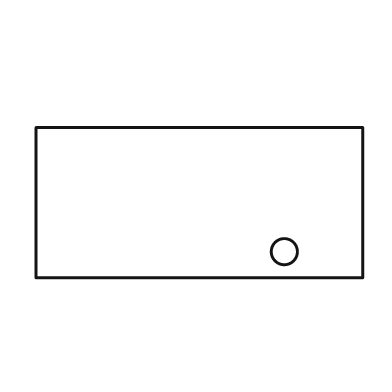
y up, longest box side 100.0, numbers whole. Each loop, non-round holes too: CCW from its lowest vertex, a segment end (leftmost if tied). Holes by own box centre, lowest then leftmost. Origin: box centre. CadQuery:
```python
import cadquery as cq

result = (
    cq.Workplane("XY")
    .moveTo(-50.0, -23.0)
    .lineTo(50.0, -23.0)
    .lineTo(50.0, 23.0)
    .lineTo(-50.0, 23.0)
    .close()
    .moveTo(26.0, -15.0)
    .circle(4.0)
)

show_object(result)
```